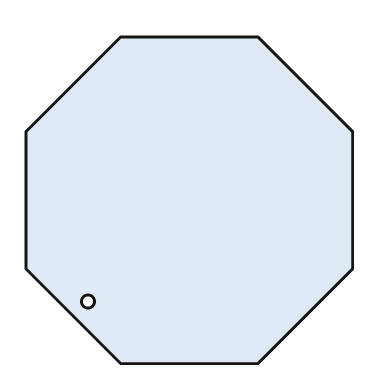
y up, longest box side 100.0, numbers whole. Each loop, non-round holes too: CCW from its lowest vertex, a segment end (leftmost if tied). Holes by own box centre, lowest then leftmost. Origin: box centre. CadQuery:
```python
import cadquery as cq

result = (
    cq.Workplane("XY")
    .moveTo(-21.0, -50.0)
    .lineTo(21.0, -50.0)
    .lineTo(50.0, -21.0)
    .lineTo(50.0, 21.0)
    .lineTo(21.0, 50.0)
    .lineTo(-21.0, 50.0)
    .lineTo(-50.0, 21.0)
    .lineTo(-50.0, -21.0)
    .close()
    .moveTo(-31.0, -31.0)
    .circle(2.0)
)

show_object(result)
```